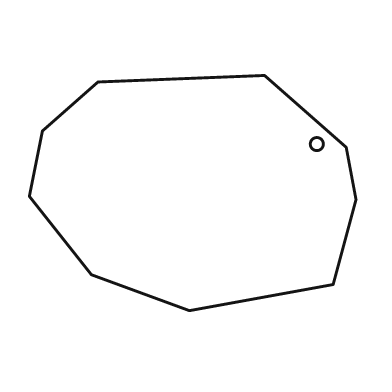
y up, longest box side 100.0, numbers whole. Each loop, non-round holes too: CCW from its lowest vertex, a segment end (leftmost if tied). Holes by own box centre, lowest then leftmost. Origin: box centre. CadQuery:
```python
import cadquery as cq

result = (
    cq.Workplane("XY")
    .moveTo(-1.0, -36.0)
    .lineTo(43.0, -28.0)
    .lineTo(50.0, -2.0)
    .lineTo(47.0, 14.0)
    .lineTo(22.0, 36.0)
    .lineTo(-29.0, 34.0)
    .lineTo(-46.0, 19.0)
    .lineTo(-50.0, -1.0)
    .lineTo(-31.0, -25.0)
    .close()
    .moveTo(38.0, 15.0)
    .circle(2.0)
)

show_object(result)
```